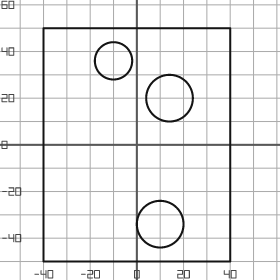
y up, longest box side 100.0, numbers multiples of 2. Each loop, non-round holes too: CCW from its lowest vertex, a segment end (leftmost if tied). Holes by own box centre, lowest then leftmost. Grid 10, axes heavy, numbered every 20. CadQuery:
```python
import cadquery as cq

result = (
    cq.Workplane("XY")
    .moveTo(-40.0, -50.0)
    .lineTo(40.0, -50.0)
    .lineTo(40.0, 50.0)
    .lineTo(-40.0, 50.0)
    .close()
    .moveTo(10.0, -34.0)
    .circle(10.0)
    .moveTo(14.0, 20.0)
    .circle(10.0)
    .moveTo(-10.0, 36.0)
    .circle(8.0)
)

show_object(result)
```